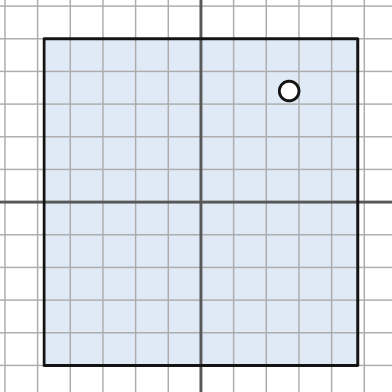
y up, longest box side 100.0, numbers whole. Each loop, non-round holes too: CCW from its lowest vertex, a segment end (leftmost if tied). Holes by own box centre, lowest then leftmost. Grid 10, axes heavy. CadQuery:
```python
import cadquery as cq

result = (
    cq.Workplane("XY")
    .moveTo(-48.0, -50.0)
    .lineTo(48.0, -50.0)
    .lineTo(48.0, 50.0)
    .lineTo(-48.0, 50.0)
    .close()
    .moveTo(27.0, 34.0)
    .circle(3.0)
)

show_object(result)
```